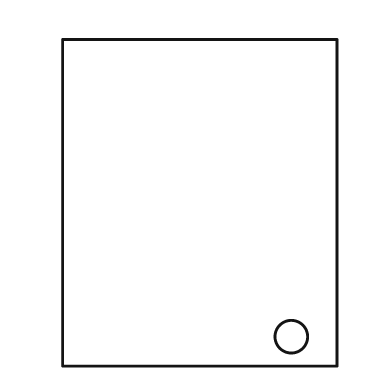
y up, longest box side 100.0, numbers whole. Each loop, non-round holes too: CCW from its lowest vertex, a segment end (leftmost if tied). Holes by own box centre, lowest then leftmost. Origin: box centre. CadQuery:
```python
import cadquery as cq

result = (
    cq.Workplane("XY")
    .moveTo(-42.0, -50.0)
    .lineTo(42.0, -50.0)
    .lineTo(42.0, 50.0)
    .lineTo(-42.0, 50.0)
    .close()
    .moveTo(28.0, -41.0)
    .circle(5.0)
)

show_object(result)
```